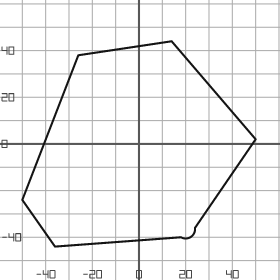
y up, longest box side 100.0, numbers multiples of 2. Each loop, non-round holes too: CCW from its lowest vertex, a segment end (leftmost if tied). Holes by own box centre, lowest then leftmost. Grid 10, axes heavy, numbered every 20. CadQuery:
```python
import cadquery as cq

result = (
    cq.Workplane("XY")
    .moveTo(-36.0, -44.0)
    .lineTo(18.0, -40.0)
    .threePointArc((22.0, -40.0), (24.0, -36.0))
    .lineTo(50.0, 2.0)
    .lineTo(14.0, 44.0)
    .lineTo(-26.0, 38.0)
    .lineTo(-50.0, -24.0)
    .close()
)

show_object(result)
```